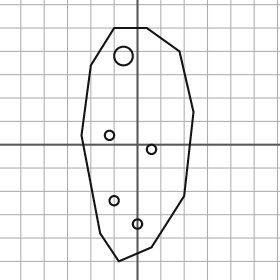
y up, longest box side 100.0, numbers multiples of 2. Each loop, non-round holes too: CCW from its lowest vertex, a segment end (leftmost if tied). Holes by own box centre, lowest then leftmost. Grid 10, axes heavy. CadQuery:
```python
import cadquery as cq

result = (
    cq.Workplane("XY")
    .moveTo(-8.0, -50.0)
    .lineTo(6.0, -44.0)
    .lineTo(20.0, -22.0)
    .lineTo(24.0, 14.0)
    .lineTo(18.0, 40.0)
    .lineTo(4.0, 50.0)
    .lineTo(-10.0, 50.0)
    .lineTo(-20.0, 34.0)
    .lineTo(-24.0, 4.0)
    .lineTo(-16.0, -38.0)
    .close()
    .moveTo(0.0, -34.0)
    .circle(2.0)
    .moveTo(-10.0, -24.0)
    .circle(2.0)
    .moveTo(6.0, -2.0)
    .circle(2.0)
    .moveTo(-12.0, 4.0)
    .circle(2.0)
    .moveTo(-6.0, 38.0)
    .circle(4.0)
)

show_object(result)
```